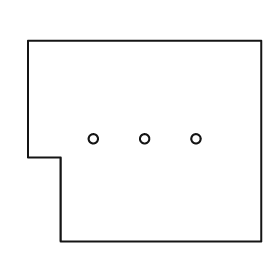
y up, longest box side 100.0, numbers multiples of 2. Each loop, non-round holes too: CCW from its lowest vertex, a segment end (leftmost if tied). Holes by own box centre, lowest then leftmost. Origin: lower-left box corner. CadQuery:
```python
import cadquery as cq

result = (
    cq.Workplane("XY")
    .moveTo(14.0, 0.0)
    .lineTo(100.0, 0.0)
    .lineTo(100.0, 86.0)
    .lineTo(0.0, 86.0)
    .lineTo(0.0, 36.0)
    .lineTo(14.0, 36.0)
    .close()
    .moveTo(28.0, 44.0)
    .circle(2.0)
    .moveTo(50.0, 44.0)
    .circle(2.0)
    .moveTo(72.0, 44.0)
    .circle(2.0)
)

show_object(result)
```